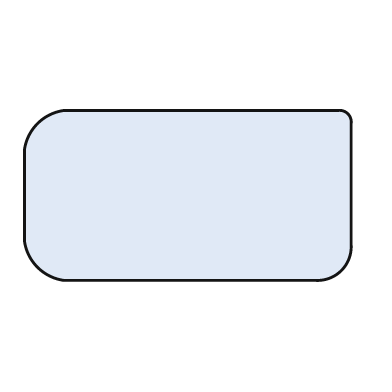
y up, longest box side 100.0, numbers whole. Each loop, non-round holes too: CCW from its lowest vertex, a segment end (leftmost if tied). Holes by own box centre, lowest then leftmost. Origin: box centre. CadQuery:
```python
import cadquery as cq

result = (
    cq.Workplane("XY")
    .moveTo(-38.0, -26.0)
    .lineTo(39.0, -26.0)
    .threePointArc((47.0, -23.0), (50.0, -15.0))
    .lineTo(50.0, 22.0)
    .threePointArc((49.0, 25.0), (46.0, 26.0))
    .lineTo(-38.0, 26.0)
    .threePointArc((-46.0, 22.0), (-50.0, 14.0))
    .lineTo(-50.0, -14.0)
    .threePointArc((-46.0, -22.0), (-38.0, -26.0))
    .close()
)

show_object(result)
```